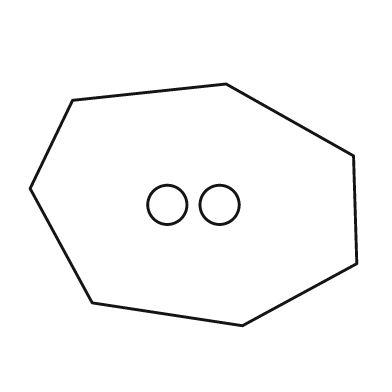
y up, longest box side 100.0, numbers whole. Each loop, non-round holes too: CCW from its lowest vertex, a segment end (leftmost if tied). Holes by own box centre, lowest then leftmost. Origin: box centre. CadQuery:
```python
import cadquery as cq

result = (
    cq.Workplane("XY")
    .moveTo(15.0, -37.0)
    .lineTo(50.0, -18.0)
    .lineTo(49.0, 15.0)
    .lineTo(10.0, 37.0)
    .lineTo(-37.0, 32.0)
    .lineTo(-50.0, 5.0)
    .lineTo(-31.0, -30.0)
    .close()
    .moveTo(-8.0, 0.0)
    .circle(6.0)
    .moveTo(8.0, 0.0)
    .circle(6.0)
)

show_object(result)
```